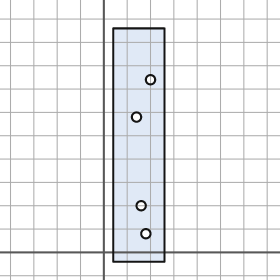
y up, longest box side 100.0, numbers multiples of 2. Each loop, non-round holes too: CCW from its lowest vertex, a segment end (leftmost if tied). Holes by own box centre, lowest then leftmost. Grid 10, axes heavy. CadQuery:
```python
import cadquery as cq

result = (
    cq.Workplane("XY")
    .moveTo(4.0, -4.0)
    .lineTo(26.0, -4.0)
    .lineTo(26.0, 96.0)
    .lineTo(4.0, 96.0)
    .close()
    .moveTo(18.0, 8.0)
    .circle(2.0)
    .moveTo(16.0, 20.0)
    .circle(2.0)
    .moveTo(14.0, 58.0)
    .circle(2.0)
    .moveTo(20.0, 74.0)
    .circle(2.0)
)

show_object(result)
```